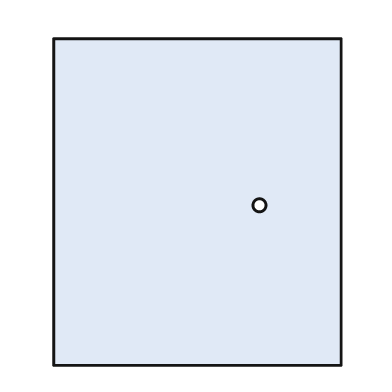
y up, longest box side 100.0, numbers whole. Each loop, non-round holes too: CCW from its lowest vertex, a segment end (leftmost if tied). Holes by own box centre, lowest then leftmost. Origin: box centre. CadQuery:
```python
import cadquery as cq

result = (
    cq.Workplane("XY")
    .moveTo(-44.0, -50.0)
    .lineTo(44.0, -50.0)
    .lineTo(44.0, 50.0)
    .lineTo(-44.0, 50.0)
    .close()
    .moveTo(19.0, -1.0)
    .circle(2.0)
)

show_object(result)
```